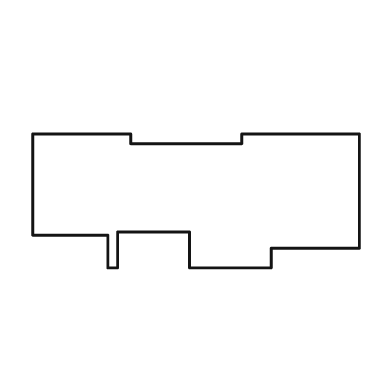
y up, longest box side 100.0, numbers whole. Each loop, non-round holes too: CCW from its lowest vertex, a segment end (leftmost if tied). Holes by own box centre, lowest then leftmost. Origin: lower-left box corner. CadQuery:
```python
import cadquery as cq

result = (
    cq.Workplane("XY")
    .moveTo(23.0, 0.0)
    .lineTo(26.0, 0.0)
    .lineTo(26.0, 11.0)
    .lineTo(48.0, 11.0)
    .lineTo(48.0, 0.0)
    .lineTo(73.0, 0.0)
    .lineTo(73.0, 6.0)
    .lineTo(100.0, 6.0)
    .lineTo(100.0, 41.0)
    .lineTo(64.0, 41.0)
    .lineTo(64.0, 38.0)
    .lineTo(30.0, 38.0)
    .lineTo(30.0, 41.0)
    .lineTo(0.0, 41.0)
    .lineTo(0.0, 10.0)
    .lineTo(23.0, 10.0)
    .close()
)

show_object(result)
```